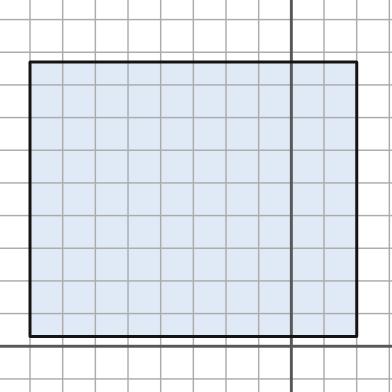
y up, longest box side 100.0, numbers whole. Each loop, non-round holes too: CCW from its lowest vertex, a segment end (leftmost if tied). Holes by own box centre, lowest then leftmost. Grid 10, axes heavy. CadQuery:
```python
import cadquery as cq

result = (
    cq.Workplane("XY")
    .moveTo(-80.0, 3.0)
    .lineTo(20.0, 3.0)
    .lineTo(20.0, 87.0)
    .lineTo(-80.0, 87.0)
    .close()
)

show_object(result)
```